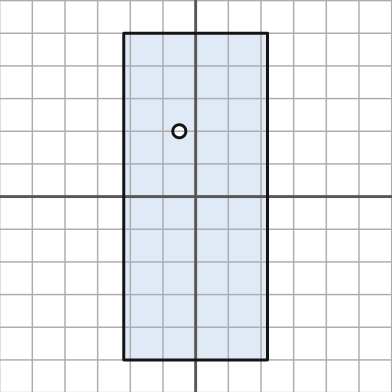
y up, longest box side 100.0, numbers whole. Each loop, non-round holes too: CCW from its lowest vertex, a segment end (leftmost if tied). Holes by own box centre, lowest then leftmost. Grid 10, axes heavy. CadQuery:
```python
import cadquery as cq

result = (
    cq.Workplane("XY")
    .moveTo(-22.0, -50.0)
    .lineTo(22.0, -50.0)
    .lineTo(22.0, 50.0)
    .lineTo(-22.0, 50.0)
    .close()
    .moveTo(-5.0, 20.0)
    .circle(2.0)
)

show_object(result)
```